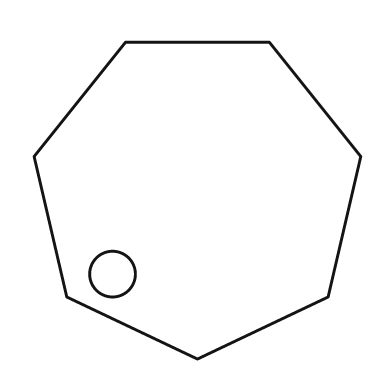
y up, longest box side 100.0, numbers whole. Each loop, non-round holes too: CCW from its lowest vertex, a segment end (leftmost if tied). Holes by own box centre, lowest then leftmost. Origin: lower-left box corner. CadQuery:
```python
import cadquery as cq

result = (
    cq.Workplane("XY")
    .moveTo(50.0, 0.0)
    .lineTo(90.0, 19.0)
    .lineTo(100.0, 62.0)
    .lineTo(72.0, 97.0)
    .lineTo(28.0, 97.0)
    .lineTo(0.0, 62.0)
    .lineTo(10.0, 19.0)
    .close()
    .moveTo(24.0, 26.0)
    .circle(7.0)
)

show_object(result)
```